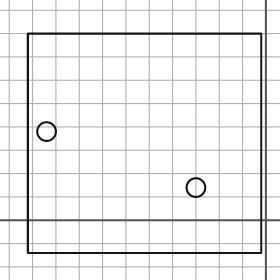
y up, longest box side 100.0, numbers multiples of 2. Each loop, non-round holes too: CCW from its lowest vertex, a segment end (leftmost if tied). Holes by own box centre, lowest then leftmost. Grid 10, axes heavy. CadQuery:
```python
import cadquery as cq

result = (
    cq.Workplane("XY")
    .moveTo(-102.0, -14.0)
    .lineTo(-2.0, -14.0)
    .lineTo(-2.0, 80.0)
    .lineTo(-102.0, 80.0)
    .close()
    .moveTo(-30.0, 14.0)
    .circle(4.0)
    .moveTo(-94.0, 38.0)
    .circle(4.0)
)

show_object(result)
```